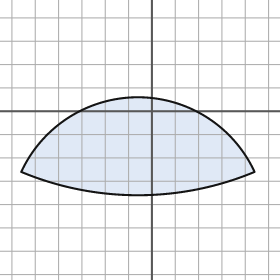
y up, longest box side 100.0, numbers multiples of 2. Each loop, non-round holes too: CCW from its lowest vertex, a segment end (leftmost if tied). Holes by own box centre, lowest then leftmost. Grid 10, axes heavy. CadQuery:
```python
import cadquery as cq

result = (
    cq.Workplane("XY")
    .moveTo(-56.0, -26.0)
    .threePointArc((-6.0, -36.0), (44.0, -26.0))
    .threePointArc((-6.0, 6.0), (-56.0, -26.0))
    .close()
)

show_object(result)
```